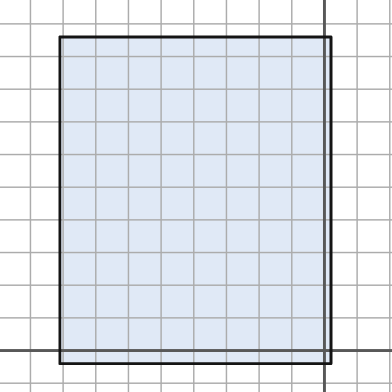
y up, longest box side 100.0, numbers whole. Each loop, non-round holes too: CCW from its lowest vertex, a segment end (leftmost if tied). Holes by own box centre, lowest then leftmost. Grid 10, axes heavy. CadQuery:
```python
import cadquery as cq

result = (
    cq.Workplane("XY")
    .moveTo(-81.0, -4.0)
    .lineTo(2.0, -4.0)
    .lineTo(2.0, 96.0)
    .lineTo(-81.0, 96.0)
    .close()
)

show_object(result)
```